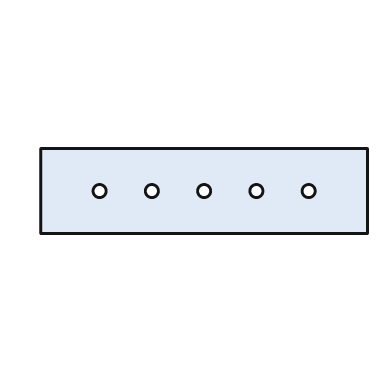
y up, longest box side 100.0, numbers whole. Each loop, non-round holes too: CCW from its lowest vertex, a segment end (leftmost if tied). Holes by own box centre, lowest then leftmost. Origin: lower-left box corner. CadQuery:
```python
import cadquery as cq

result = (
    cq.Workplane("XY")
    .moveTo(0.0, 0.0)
    .lineTo(100.0, 0.0)
    .lineTo(100.0, 26.0)
    .lineTo(0.0, 26.0)
    .close()
    .moveTo(18.0, 13.0)
    .circle(2.0)
    .moveTo(34.0, 13.0)
    .circle(2.0)
    .moveTo(50.0, 13.0)
    .circle(2.0)
    .moveTo(66.0, 13.0)
    .circle(2.0)
    .moveTo(82.0, 13.0)
    .circle(2.0)
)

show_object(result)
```